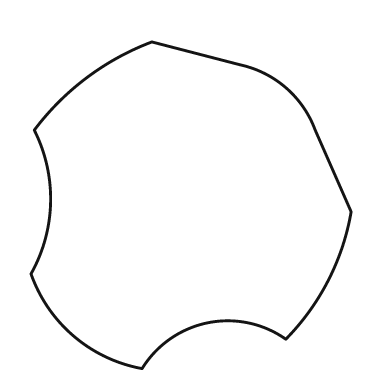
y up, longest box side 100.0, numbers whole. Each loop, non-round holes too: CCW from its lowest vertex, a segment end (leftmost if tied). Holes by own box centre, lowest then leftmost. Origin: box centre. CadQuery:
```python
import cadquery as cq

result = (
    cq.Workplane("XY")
    .moveTo(-15.0, -50.0)
    .threePointArc((5.0, -36.0), (29.0, -41.0))
    .threePointArc((42.0, -23.0), (49.0, -2.0))
    .lineTo(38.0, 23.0)
    .threePointArc((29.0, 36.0), (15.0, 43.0))
    .lineTo(-12.0, 50.0)
    .threePointArc((-32.0, 39.0), (-48.0, 23.0))
    .threePointArc((-43.0, 1.0), (-49.0, -21.0))
    .threePointArc((-36.0, -40.0), (-15.0, -50.0))
    .close()
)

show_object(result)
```